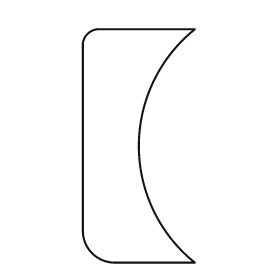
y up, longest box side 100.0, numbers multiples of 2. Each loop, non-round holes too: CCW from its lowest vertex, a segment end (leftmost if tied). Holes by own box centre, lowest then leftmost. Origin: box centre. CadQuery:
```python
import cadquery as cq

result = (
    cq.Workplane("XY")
    .moveTo(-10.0, -50.0)
    .lineTo(24.0, -50.0)
    .threePointArc((0.0, 0.0), (24.0, 50.0))
    .lineTo(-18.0, 50.0)
    .threePointArc((-22.0, 48.0), (-24.0, 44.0))
    .lineTo(-24.0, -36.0)
    .threePointArc((-20.0, -46.0), (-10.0, -50.0))
    .close()
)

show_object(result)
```